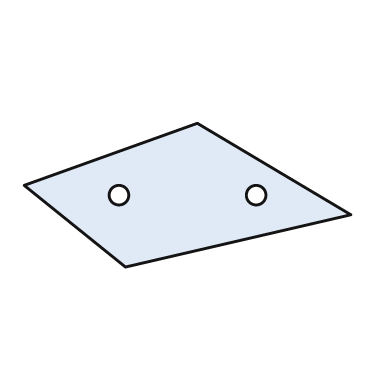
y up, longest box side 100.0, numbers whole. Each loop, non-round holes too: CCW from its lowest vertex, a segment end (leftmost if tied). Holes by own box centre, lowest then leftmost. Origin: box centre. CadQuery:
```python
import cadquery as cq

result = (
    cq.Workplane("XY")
    .moveTo(-19.0, -22.0)
    .lineTo(50.0, -6.0)
    .lineTo(3.0, 22.0)
    .lineTo(-50.0, 3.0)
    .close()
    .moveTo(-21.0, 0.0)
    .circle(3.0)
    .moveTo(21.0, 0.0)
    .circle(3.0)
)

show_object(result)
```